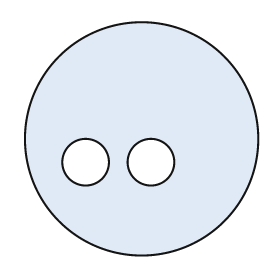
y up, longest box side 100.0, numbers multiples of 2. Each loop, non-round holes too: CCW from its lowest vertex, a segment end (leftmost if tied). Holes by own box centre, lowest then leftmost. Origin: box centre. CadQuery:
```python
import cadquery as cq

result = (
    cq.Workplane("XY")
    .moveTo(0.0, 0.0)
    .circle(50.0)
    .moveTo(-24.0, -10.0)
    .circle(10.0)
    .moveTo(4.0, -10.0)
    .circle(10.0)
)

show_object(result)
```